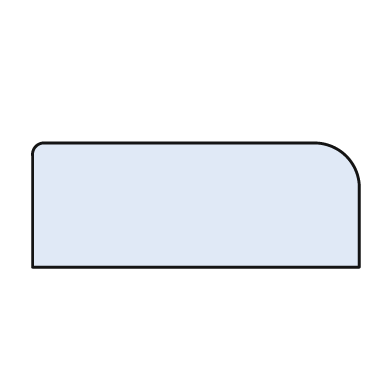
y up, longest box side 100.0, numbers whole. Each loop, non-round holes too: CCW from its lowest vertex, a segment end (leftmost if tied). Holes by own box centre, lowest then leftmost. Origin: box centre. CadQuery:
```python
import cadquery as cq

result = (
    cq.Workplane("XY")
    .moveTo(-50.0, -19.0)
    .lineTo(50.0, -19.0)
    .lineTo(50.0, 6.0)
    .threePointArc((46.0, 15.0), (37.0, 19.0))
    .lineTo(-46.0, 19.0)
    .threePointArc((-49.0, 18.0), (-50.0, 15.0))
    .close()
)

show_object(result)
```